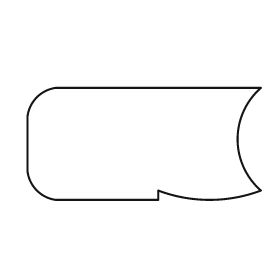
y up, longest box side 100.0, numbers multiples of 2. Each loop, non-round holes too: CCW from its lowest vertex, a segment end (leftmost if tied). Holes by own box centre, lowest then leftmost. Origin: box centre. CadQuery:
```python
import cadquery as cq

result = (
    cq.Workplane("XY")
    .moveTo(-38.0, -24.0)
    .lineTo(6.0, -24.0)
    .lineTo(6.0, -20.0)
    .threePointArc((28.0, -24.0), (50.0, -20.0))
    .threePointArc((40.0, 2.0), (50.0, 24.0))
    .lineTo(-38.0, 24.0)
    .threePointArc((-46.0, 20.0), (-50.0, 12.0))
    .lineTo(-50.0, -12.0)
    .threePointArc((-46.0, -20.0), (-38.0, -24.0))
    .close()
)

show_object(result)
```